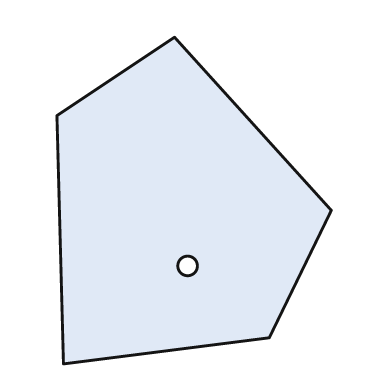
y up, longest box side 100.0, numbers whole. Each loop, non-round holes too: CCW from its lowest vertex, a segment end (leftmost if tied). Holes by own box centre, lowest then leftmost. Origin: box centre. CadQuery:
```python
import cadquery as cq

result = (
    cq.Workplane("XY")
    .moveTo(-40.0, -50.0)
    .lineTo(23.0, -42.0)
    .lineTo(42.0, -3.0)
    .lineTo(-6.0, 50.0)
    .lineTo(-42.0, 26.0)
    .close()
    .moveTo(-2.0, -20.0)
    .circle(3.0)
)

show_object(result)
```